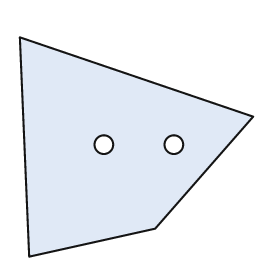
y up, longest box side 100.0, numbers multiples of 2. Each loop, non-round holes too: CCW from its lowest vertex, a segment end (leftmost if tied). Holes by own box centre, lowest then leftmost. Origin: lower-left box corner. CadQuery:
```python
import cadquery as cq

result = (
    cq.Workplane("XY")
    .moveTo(4.0, 0.0)
    .lineTo(58.0, 12.0)
    .lineTo(100.0, 60.0)
    .lineTo(0.0, 94.0)
    .close()
    .moveTo(36.0, 48.0)
    .circle(4.0)
    .moveTo(66.0, 48.0)
    .circle(4.0)
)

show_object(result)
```